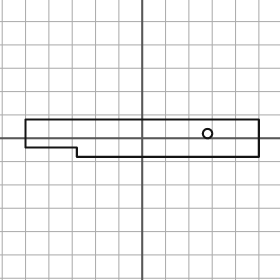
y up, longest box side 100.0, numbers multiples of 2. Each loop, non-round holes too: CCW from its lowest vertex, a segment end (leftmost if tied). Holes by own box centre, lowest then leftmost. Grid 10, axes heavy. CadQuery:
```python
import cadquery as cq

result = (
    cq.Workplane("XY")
    .moveTo(-28.0, -8.0)
    .lineTo(50.0, -8.0)
    .lineTo(50.0, 8.0)
    .lineTo(-50.0, 8.0)
    .lineTo(-50.0, -4.0)
    .lineTo(-28.0, -4.0)
    .close()
    .moveTo(28.0, 2.0)
    .circle(2.0)
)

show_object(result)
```